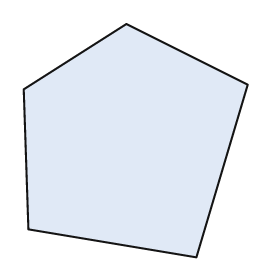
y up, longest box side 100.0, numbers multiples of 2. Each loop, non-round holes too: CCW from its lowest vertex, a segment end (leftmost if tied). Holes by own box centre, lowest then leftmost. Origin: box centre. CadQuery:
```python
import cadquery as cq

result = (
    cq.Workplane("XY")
    .moveTo(26.0, -50.0)
    .lineTo(48.0, 24.0)
    .lineTo(-4.0, 50.0)
    .lineTo(-48.0, 22.0)
    .lineTo(-46.0, -38.0)
    .close()
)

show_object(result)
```